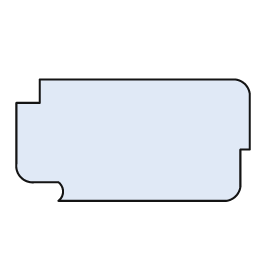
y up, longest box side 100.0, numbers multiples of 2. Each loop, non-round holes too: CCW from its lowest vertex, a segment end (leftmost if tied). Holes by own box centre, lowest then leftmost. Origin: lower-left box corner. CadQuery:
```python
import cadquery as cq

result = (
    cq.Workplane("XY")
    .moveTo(18.0, 0.0)
    .lineTo(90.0, 0.0)
    .threePointArc((94.0, 2.0), (96.0, 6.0))
    .lineTo(96.0, 22.0)
    .lineTo(100.0, 22.0)
    .lineTo(100.0, 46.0)
    .threePointArc((98.0, 50.0), (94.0, 52.0))
    .lineTo(10.0, 52.0)
    .lineTo(10.0, 42.0)
    .lineTo(0.0, 42.0)
    .lineTo(0.0, 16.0)
    .threePointArc((2.0, 10.0), (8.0, 8.0))
    .lineTo(18.0, 8.0)
    .threePointArc((20.0, 4.0), (18.0, 0.0))
    .close()
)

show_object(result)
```